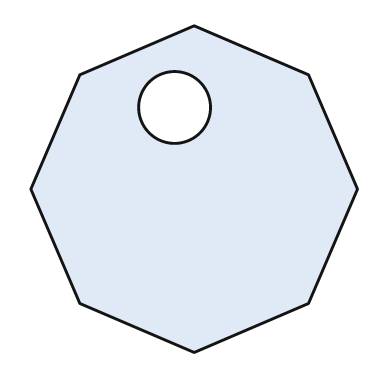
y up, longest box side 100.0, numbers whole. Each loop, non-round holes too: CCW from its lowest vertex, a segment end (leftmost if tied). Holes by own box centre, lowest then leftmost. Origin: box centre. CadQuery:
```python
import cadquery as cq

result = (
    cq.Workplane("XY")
    .moveTo(0.0, -50.0)
    .lineTo(35.0, -35.0)
    .lineTo(50.0, 0.0)
    .lineTo(35.0, 35.0)
    .lineTo(0.0, 50.0)
    .lineTo(-35.0, 35.0)
    .lineTo(-50.0, 0.0)
    .lineTo(-35.0, -35.0)
    .close()
    .moveTo(-6.0, 25.0)
    .circle(11.0)
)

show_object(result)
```